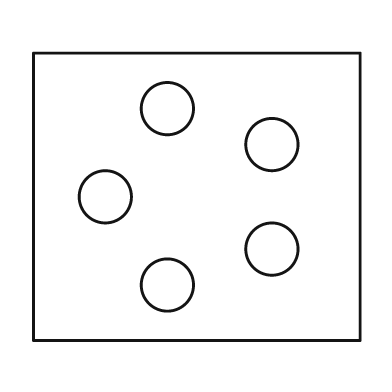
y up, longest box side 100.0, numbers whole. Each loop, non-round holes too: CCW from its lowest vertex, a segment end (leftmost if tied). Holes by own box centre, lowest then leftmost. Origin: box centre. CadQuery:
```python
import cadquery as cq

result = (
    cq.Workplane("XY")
    .moveTo(-50.0, -44.0)
    .lineTo(50.0, -44.0)
    .lineTo(50.0, 44.0)
    .lineTo(-50.0, 44.0)
    .close()
    .moveTo(-9.0, -27.0)
    .circle(8.0)
    .moveTo(23.0, -16.0)
    .circle(8.0)
    .moveTo(-28.0, 0.0)
    .circle(8.0)
    .moveTo(23.0, 16.0)
    .circle(8.0)
    .moveTo(-9.0, 27.0)
    .circle(8.0)
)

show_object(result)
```